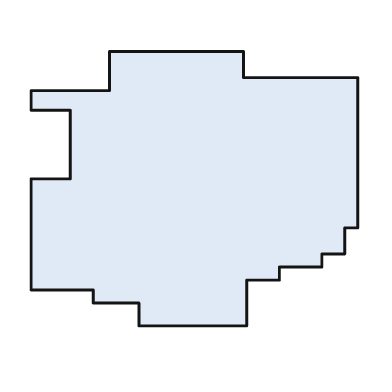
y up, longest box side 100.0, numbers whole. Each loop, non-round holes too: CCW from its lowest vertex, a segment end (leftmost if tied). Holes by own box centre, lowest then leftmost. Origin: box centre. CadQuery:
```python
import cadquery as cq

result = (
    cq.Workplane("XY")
    .moveTo(-17.0, -42.0)
    .lineTo(16.0, -42.0)
    .lineTo(16.0, -28.0)
    .lineTo(26.0, -28.0)
    .lineTo(26.0, -24.0)
    .lineTo(39.0, -24.0)
    .lineTo(39.0, -20.0)
    .lineTo(46.0, -20.0)
    .lineTo(46.0, -12.0)
    .lineTo(50.0, -12.0)
    .lineTo(50.0, 34.0)
    .lineTo(15.0, 34.0)
    .lineTo(15.0, 42.0)
    .lineTo(-26.0, 42.0)
    .lineTo(-26.0, 30.0)
    .lineTo(-50.0, 30.0)
    .lineTo(-50.0, 24.0)
    .lineTo(-38.0, 24.0)
    .lineTo(-38.0, 3.0)
    .lineTo(-50.0, 3.0)
    .lineTo(-50.0, -31.0)
    .lineTo(-31.0, -31.0)
    .lineTo(-31.0, -35.0)
    .lineTo(-17.0, -35.0)
    .close()
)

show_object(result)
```